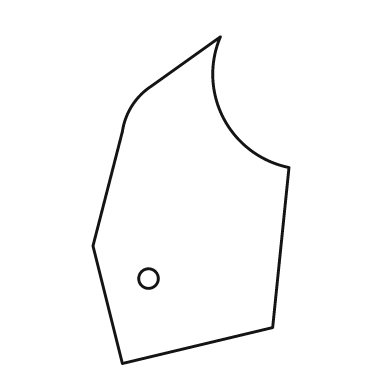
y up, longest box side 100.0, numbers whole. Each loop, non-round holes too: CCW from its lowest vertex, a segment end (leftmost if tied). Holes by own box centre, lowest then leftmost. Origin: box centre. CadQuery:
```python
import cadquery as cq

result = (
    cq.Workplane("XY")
    .moveTo(-21.0, -50.0)
    .lineTo(25.0, -39.0)
    .lineTo(30.0, 10.0)
    .threePointArc((10.0, 25.0), (9.0, 50.0))
    .lineTo(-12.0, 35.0)
    .threePointArc((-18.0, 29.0), (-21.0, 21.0))
    .lineTo(-30.0, -14.0)
    .close()
    .moveTo(-13.0, -24.0)
    .circle(3.0)
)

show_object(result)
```